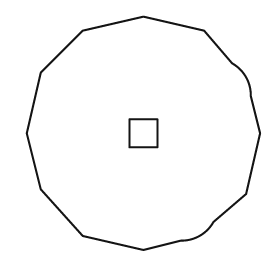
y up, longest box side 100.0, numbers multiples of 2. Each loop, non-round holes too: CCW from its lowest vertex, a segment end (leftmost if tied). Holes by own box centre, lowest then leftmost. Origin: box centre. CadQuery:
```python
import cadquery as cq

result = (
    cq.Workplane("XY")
    .moveTo(0.0, -50.0)
    .lineTo(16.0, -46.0)
    .threePointArc((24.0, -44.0), (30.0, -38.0))
    .lineTo(44.0, -26.0)
    .lineTo(50.0, 0.0)
    .lineTo(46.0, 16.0)
    .threePointArc((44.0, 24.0), (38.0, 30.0))
    .lineTo(26.0, 44.0)
    .lineTo(0.0, 50.0)
    .lineTo(-26.0, 44.0)
    .lineTo(-44.0, 26.0)
    .lineTo(-50.0, 0.0)
    .lineTo(-44.0, -24.0)
    .lineTo(-26.0, -44.0)
    .close()
    .moveTo(-6.0, -6.0)
    .lineTo(6.0, -6.0)
    .lineTo(6.0, 6.0)
    .lineTo(-6.0, 6.0)
    .close()
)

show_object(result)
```